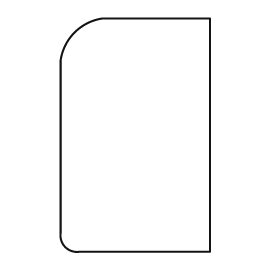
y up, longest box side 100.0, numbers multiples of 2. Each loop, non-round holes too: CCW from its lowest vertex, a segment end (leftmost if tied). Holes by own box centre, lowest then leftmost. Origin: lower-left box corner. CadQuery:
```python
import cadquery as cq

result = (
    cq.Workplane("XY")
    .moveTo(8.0, 0.0)
    .lineTo(64.0, 0.0)
    .lineTo(64.0, 100.0)
    .lineTo(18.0, 100.0)
    .threePointArc((6.0, 94.0), (0.0, 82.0))
    .lineTo(0.0, 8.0)
    .threePointArc((2.0, 2.0), (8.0, 0.0))
    .close()
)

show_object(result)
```